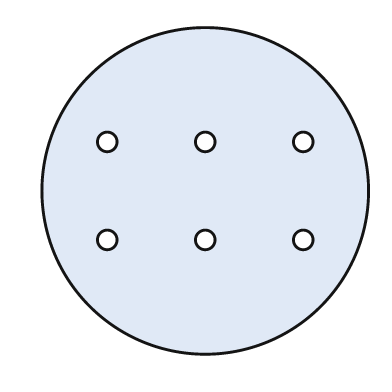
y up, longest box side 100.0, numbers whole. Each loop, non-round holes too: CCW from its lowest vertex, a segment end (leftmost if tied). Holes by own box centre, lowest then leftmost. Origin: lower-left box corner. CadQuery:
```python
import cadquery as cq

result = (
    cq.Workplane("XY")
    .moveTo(50.0, 50.0)
    .circle(50.0)
    .moveTo(20.0, 35.0)
    .circle(3.0)
    .moveTo(50.0, 35.0)
    .circle(3.0)
    .moveTo(80.0, 35.0)
    .circle(3.0)
    .moveTo(20.0, 65.0)
    .circle(3.0)
    .moveTo(50.0, 65.0)
    .circle(3.0)
    .moveTo(80.0, 65.0)
    .circle(3.0)
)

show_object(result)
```